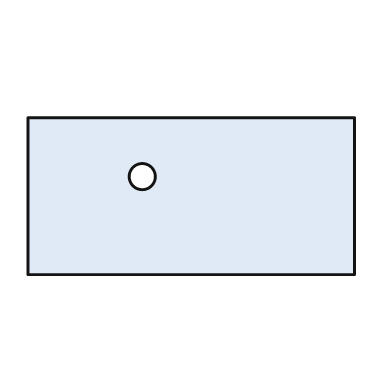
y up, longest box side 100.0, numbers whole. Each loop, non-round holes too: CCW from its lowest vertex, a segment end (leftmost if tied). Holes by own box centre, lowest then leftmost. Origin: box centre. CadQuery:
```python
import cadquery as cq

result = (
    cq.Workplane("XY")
    .moveTo(-50.0, -24.0)
    .lineTo(50.0, -24.0)
    .lineTo(50.0, 24.0)
    .lineTo(-50.0, 24.0)
    .close()
    .moveTo(-15.0, 6.0)
    .circle(4.0)
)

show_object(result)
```